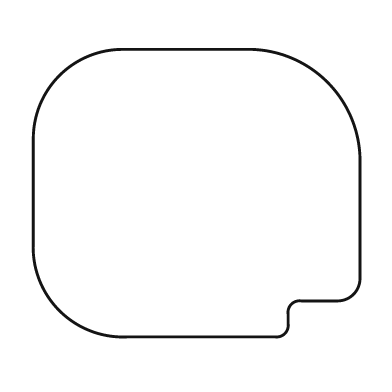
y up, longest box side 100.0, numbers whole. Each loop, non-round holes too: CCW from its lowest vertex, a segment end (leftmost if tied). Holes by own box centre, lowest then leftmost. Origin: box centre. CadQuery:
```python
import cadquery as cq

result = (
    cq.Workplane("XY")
    .moveTo(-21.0, -44.0)
    .lineTo(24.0, -44.0)
    .threePointArc((27.0, -43.0), (28.0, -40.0))
    .lineTo(28.0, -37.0)
    .threePointArc((29.0, -34.0), (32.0, -33.0))
    .lineTo(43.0, -33.0)
    .threePointArc((48.0, -31.0), (50.0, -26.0))
    .lineTo(50.0, 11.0)
    .threePointArc((40.0, 34.0), (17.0, 44.0))
    .lineTo(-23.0, 44.0)
    .threePointArc((-42.0, 36.0), (-50.0, 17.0))
    .lineTo(-50.0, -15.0)
    .threePointArc((-42.0, -36.0), (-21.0, -44.0))
    .close()
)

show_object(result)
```